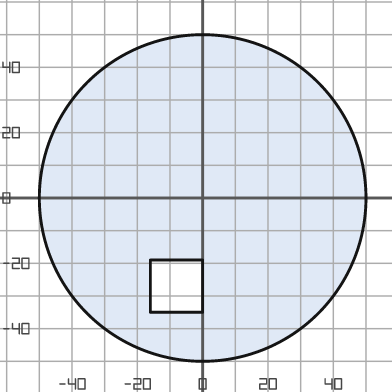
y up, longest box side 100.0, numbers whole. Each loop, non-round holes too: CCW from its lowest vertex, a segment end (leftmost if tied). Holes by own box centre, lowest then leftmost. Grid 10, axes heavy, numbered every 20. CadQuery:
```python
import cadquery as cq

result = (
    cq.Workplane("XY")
    .moveTo(0.0, 0.0)
    .circle(50.0)
    .moveTo(-16.0, -35.0)
    .lineTo(0.0, -35.0)
    .lineTo(0.0, -19.0)
    .lineTo(-16.0, -19.0)
    .close()
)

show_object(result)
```